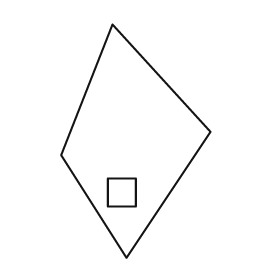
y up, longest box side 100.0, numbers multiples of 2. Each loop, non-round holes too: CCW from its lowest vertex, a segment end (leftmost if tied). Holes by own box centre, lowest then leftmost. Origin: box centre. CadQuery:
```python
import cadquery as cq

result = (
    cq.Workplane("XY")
    .moveTo(-4.0, -50.0)
    .lineTo(32.0, 4.0)
    .lineTo(-10.0, 50.0)
    .lineTo(-32.0, -6.0)
    .close()
    .moveTo(-12.0, -28.0)
    .lineTo(0.0, -28.0)
    .lineTo(0.0, -16.0)
    .lineTo(-12.0, -16.0)
    .close()
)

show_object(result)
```